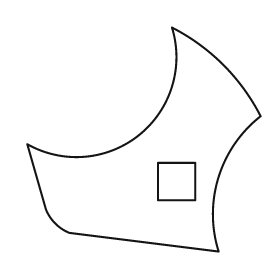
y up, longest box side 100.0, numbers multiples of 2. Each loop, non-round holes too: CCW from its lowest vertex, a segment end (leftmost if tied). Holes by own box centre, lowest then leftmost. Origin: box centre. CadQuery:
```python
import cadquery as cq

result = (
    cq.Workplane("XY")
    .moveTo(32.0, -48.0)
    .threePointArc((32.0, -16.0), (50.0, 10.0))
    .threePointArc((34.0, 32.0), (12.0, 48.0))
    .threePointArc((-2.0, 2.0), (-50.0, -2.0))
    .lineTo(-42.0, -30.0)
    .threePointArc((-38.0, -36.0), (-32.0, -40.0))
    .close()
    .moveTo(6.0, -26.0)
    .lineTo(22.0, -26.0)
    .lineTo(22.0, -10.0)
    .lineTo(6.0, -10.0)
    .close()
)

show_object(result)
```